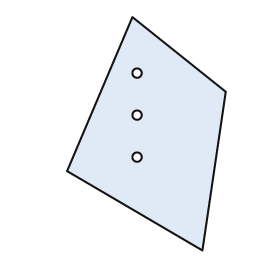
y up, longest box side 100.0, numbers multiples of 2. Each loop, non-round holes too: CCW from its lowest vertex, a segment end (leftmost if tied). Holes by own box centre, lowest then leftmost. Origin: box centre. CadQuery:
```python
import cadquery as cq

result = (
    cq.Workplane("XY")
    .moveTo(24.0, -50.0)
    .lineTo(34.0, 18.0)
    .lineTo(-6.0, 50.0)
    .lineTo(-34.0, -16.0)
    .close()
    .moveTo(-4.0, -10.0)
    .circle(2.0)
    .moveTo(-4.0, 8.0)
    .circle(2.0)
    .moveTo(-4.0, 26.0)
    .circle(2.0)
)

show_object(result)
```